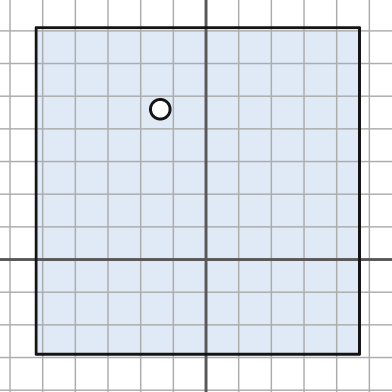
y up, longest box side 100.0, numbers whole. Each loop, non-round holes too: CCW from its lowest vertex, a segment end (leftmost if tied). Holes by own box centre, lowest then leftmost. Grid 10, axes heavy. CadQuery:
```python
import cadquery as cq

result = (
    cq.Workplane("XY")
    .moveTo(-52.0, -29.0)
    .lineTo(47.0, -29.0)
    .lineTo(47.0, 71.0)
    .lineTo(-52.0, 71.0)
    .close()
    .moveTo(-14.0, 46.0)
    .circle(3.0)
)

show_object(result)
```